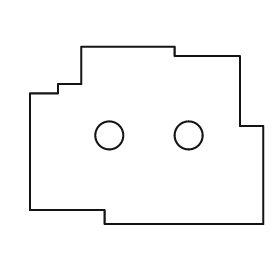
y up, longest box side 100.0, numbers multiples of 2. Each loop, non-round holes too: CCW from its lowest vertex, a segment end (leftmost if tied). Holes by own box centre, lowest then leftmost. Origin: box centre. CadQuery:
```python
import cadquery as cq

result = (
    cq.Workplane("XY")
    .moveTo(-18.0, -38.0)
    .lineTo(50.0, -38.0)
    .lineTo(50.0, 4.0)
    .lineTo(40.0, 4.0)
    .lineTo(40.0, 34.0)
    .lineTo(12.0, 34.0)
    .lineTo(12.0, 38.0)
    .lineTo(-28.0, 38.0)
    .lineTo(-28.0, 22.0)
    .lineTo(-38.0, 22.0)
    .lineTo(-38.0, 18.0)
    .lineTo(-50.0, 18.0)
    .lineTo(-50.0, -32.0)
    .lineTo(-18.0, -32.0)
    .close()
    .moveTo(-16.0, 0.0)
    .circle(6.0)
    .moveTo(18.0, 0.0)
    .circle(6.0)
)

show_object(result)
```